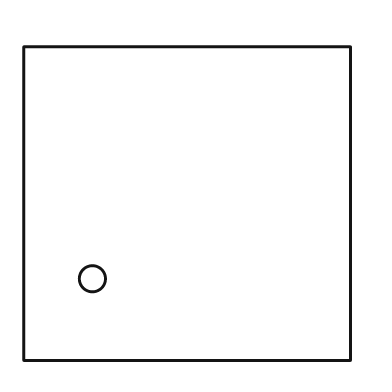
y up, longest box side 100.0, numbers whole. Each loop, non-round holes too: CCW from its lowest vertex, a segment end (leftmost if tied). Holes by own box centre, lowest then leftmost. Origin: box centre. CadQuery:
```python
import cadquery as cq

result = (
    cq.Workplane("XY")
    .moveTo(-50.0, -48.0)
    .lineTo(50.0, -48.0)
    .lineTo(50.0, 48.0)
    .lineTo(-50.0, 48.0)
    .close()
    .moveTo(-29.0, -23.0)
    .circle(4.0)
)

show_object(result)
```